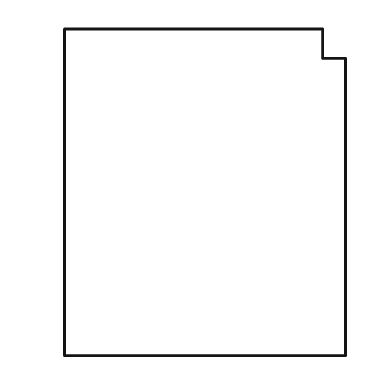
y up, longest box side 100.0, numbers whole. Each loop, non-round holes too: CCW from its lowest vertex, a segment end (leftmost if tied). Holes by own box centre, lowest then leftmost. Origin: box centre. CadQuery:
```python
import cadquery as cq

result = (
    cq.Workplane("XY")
    .moveTo(-43.0, -50.0)
    .lineTo(43.0, -50.0)
    .lineTo(43.0, 41.0)
    .lineTo(36.0, 41.0)
    .lineTo(36.0, 50.0)
    .lineTo(-43.0, 50.0)
    .close()
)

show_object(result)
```